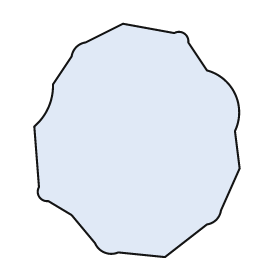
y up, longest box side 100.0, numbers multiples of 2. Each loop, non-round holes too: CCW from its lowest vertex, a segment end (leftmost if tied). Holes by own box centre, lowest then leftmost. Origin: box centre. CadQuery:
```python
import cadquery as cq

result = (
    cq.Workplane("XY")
    .moveTo(12.0, -50.0)
    .lineTo(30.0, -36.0)
    .threePointArc((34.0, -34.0), (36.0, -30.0))
    .lineTo(44.0, -12.0)
    .lineTo(42.0, 4.0)
    .threePointArc((42.0, 20.0), (30.0, 30.0))
    .lineTo(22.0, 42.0)
    .threePointArc((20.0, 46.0), (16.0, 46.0))
    .lineTo(-6.0, 50.0)
    .lineTo(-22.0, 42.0)
    .threePointArc((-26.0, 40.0), (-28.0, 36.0))
    .lineTo(-36.0, 24.0)
    .threePointArc((-38.0, 14.0), (-44.0, 6.0))
    .lineTo(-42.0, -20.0)
    .threePointArc((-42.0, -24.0), (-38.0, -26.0))
    .lineTo(-28.0, -32.0)
    .lineTo(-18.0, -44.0)
    .threePointArc((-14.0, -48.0), (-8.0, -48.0))
    .close()
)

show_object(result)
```